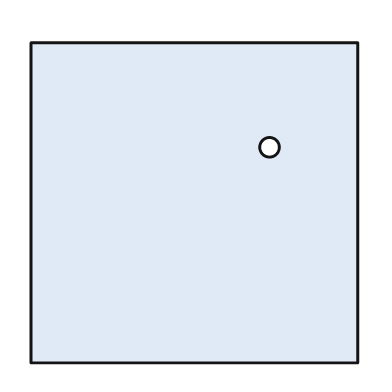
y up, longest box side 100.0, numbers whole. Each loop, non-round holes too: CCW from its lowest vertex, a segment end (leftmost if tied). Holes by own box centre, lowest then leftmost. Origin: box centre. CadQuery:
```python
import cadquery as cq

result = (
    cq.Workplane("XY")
    .moveTo(-50.0, -49.0)
    .lineTo(50.0, -49.0)
    .lineTo(50.0, 49.0)
    .lineTo(-50.0, 49.0)
    .close()
    .moveTo(23.0, 17.0)
    .circle(3.0)
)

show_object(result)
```